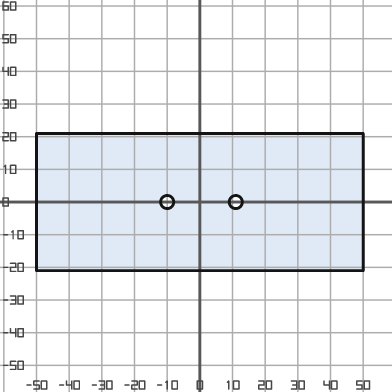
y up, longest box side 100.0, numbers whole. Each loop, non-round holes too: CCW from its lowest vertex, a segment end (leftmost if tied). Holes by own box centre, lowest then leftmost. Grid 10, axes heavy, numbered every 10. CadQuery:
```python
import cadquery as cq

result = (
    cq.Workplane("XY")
    .moveTo(-50.0, -21.0)
    .lineTo(50.0, -21.0)
    .lineTo(50.0, 21.0)
    .lineTo(-50.0, 21.0)
    .close()
    .moveTo(-10.0, 0.0)
    .circle(2.0)
    .moveTo(11.0, 0.0)
    .circle(2.0)
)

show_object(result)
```